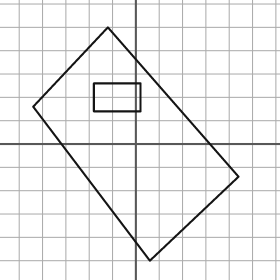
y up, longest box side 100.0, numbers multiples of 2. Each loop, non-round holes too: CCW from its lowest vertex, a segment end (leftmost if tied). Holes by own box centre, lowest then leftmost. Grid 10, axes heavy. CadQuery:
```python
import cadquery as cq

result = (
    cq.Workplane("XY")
    .moveTo(6.0, -50.0)
    .lineTo(44.0, -14.0)
    .lineTo(-12.0, 50.0)
    .lineTo(-44.0, 16.0)
    .close()
    .moveTo(-18.0, 14.0)
    .lineTo(2.0, 14.0)
    .lineTo(2.0, 26.0)
    .lineTo(-18.0, 26.0)
    .close()
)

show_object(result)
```